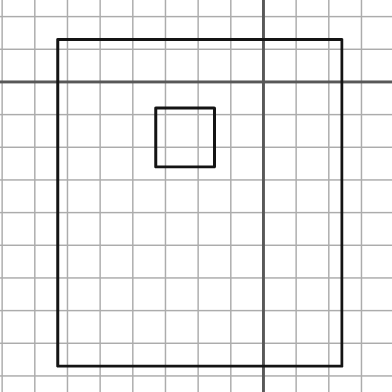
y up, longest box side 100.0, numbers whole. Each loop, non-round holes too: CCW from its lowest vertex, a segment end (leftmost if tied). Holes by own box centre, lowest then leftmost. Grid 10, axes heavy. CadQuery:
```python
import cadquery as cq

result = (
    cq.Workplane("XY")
    .moveTo(-63.0, -87.0)
    .lineTo(24.0, -87.0)
    .lineTo(24.0, 13.0)
    .lineTo(-63.0, 13.0)
    .close()
    .moveTo(-33.0, -26.0)
    .lineTo(-15.0, -26.0)
    .lineTo(-15.0, -8.0)
    .lineTo(-33.0, -8.0)
    .close()
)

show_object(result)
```